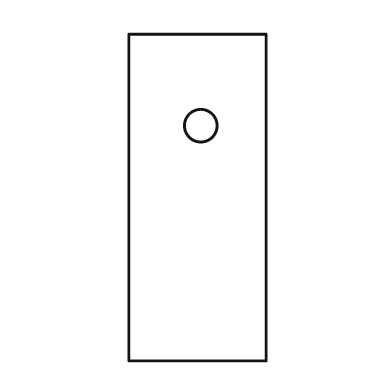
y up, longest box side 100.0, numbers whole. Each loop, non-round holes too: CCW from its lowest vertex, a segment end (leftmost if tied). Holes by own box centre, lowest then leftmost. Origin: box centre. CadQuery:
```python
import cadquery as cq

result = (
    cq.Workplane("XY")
    .moveTo(-21.0, -50.0)
    .lineTo(21.0, -50.0)
    .lineTo(21.0, 50.0)
    .lineTo(-21.0, 50.0)
    .close()
    .moveTo(1.0, 22.0)
    .circle(5.0)
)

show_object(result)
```